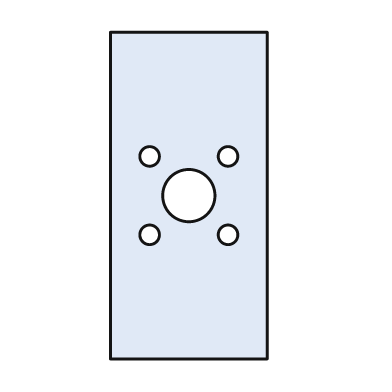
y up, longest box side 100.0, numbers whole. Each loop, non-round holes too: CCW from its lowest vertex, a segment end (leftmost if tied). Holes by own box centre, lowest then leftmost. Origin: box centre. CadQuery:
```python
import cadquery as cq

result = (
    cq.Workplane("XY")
    .moveTo(-24.0, -50.0)
    .lineTo(24.0, -50.0)
    .lineTo(24.0, 50.0)
    .lineTo(-24.0, 50.0)
    .close()
    .moveTo(-12.0, -12.0)
    .circle(3.0)
    .moveTo(12.0, -12.0)
    .circle(3.0)
    .moveTo(0.0, 0.0)
    .circle(8.0)
    .moveTo(-12.0, 12.0)
    .circle(3.0)
    .moveTo(12.0, 12.0)
    .circle(3.0)
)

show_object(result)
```